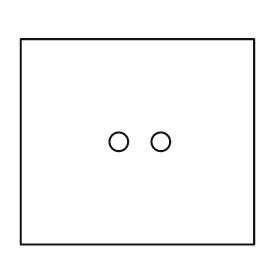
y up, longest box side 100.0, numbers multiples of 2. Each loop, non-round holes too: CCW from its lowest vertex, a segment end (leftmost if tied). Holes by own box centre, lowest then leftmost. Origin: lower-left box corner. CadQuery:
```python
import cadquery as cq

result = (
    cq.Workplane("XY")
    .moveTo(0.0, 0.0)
    .lineTo(100.0, 0.0)
    .lineTo(100.0, 88.0)
    .lineTo(0.0, 88.0)
    .close()
    .moveTo(42.0, 44.0)
    .circle(4.0)
    .moveTo(60.0, 44.0)
    .circle(4.0)
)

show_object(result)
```